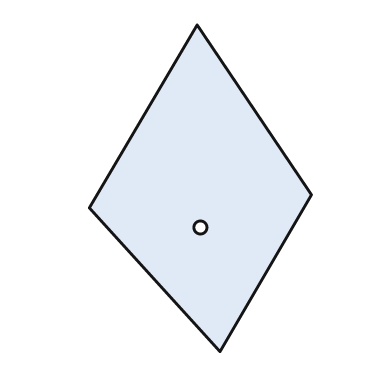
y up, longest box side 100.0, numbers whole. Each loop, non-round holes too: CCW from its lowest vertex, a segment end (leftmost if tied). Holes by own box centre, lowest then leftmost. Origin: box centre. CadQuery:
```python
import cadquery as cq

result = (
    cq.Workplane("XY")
    .moveTo(6.0, -50.0)
    .lineTo(34.0, -2.0)
    .lineTo(-1.0, 50.0)
    .lineTo(-34.0, -6.0)
    .close()
    .moveTo(0.0, -12.0)
    .circle(2.0)
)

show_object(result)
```